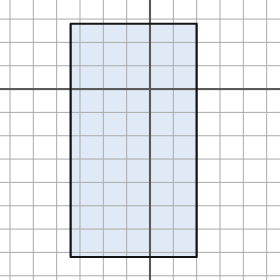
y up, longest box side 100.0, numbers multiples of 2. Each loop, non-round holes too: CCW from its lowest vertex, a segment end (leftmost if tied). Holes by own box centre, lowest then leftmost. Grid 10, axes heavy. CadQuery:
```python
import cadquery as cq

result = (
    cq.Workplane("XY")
    .moveTo(-34.0, -72.0)
    .lineTo(20.0, -72.0)
    .lineTo(20.0, 28.0)
    .lineTo(-34.0, 28.0)
    .close()
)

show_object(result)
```